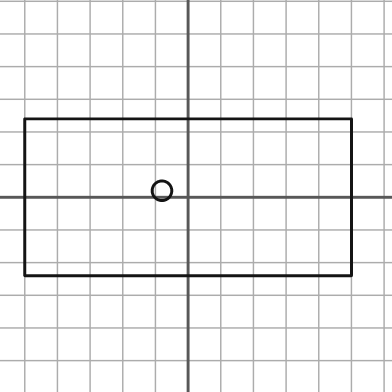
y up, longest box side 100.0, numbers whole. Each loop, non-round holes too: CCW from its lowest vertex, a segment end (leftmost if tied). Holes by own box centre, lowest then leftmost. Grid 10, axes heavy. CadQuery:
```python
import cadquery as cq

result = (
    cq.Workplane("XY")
    .moveTo(-50.0, -24.0)
    .lineTo(50.0, -24.0)
    .lineTo(50.0, 24.0)
    .lineTo(-50.0, 24.0)
    .close()
    .moveTo(-8.0, 2.0)
    .circle(3.0)
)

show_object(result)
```